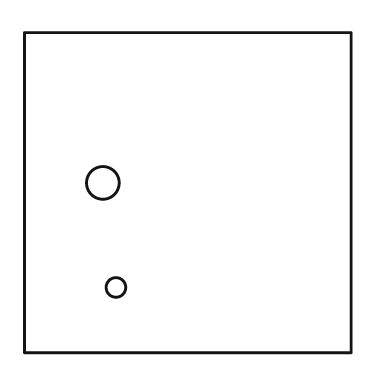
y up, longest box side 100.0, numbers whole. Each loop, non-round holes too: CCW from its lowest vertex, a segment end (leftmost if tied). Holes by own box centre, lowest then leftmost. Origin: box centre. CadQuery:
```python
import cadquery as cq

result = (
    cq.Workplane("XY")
    .moveTo(-50.0, -49.0)
    .lineTo(50.0, -49.0)
    .lineTo(50.0, 49.0)
    .lineTo(-50.0, 49.0)
    .close()
    .moveTo(-22.0, -29.0)
    .circle(3.0)
    .moveTo(-26.0, 3.0)
    .circle(5.0)
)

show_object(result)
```